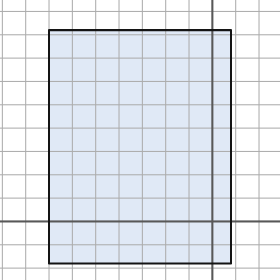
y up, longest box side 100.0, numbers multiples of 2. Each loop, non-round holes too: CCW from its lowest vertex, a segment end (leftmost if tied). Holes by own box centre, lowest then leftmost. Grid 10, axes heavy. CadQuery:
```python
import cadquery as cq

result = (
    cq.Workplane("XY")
    .moveTo(-70.0, -18.0)
    .lineTo(8.0, -18.0)
    .lineTo(8.0, 82.0)
    .lineTo(-70.0, 82.0)
    .close()
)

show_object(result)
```